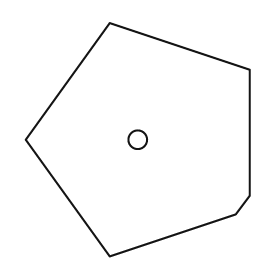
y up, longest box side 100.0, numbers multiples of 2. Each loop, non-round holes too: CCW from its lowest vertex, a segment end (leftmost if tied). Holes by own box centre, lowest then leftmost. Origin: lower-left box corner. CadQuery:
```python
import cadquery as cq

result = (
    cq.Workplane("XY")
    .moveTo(36.0, 0.0)
    .lineTo(90.0, 18.0)
    .lineTo(96.0, 26.0)
    .lineTo(96.0, 80.0)
    .lineTo(36.0, 100.0)
    .lineTo(0.0, 50.0)
    .close()
    .moveTo(48.0, 50.0)
    .circle(4.0)
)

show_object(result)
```